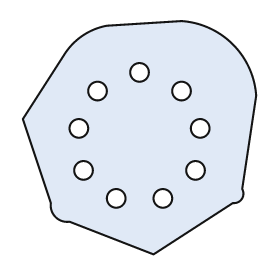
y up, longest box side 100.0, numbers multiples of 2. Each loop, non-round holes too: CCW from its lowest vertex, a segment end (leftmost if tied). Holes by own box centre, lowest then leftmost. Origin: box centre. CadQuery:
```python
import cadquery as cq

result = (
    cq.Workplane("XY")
    .moveTo(6.0, -50.0)
    .lineTo(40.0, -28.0)
    .threePointArc((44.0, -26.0), (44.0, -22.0))
    .lineTo(50.0, 18.0)
    .threePointArc((40.0, 40.0), (18.0, 50.0))
    .lineTo(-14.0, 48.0)
    .threePointArc((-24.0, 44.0), (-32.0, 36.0))
    .lineTo(-50.0, 8.0)
    .lineTo(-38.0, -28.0)
    .threePointArc((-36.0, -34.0), (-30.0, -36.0))
    .close()
    .moveTo(-10.0, -26.0)
    .circle(4.0)
    .moveTo(10.0, -26.0)
    .circle(4.0)
    .moveTo(-24.0, -14.0)
    .circle(4.0)
    .moveTo(24.0, -14.0)
    .circle(4.0)
    .moveTo(-26.0, 4.0)
    .circle(4.0)
    .moveTo(26.0, 4.0)
    .circle(4.0)
    .moveTo(-18.0, 20.0)
    .circle(4.0)
    .moveTo(18.0, 20.0)
    .circle(4.0)
    .moveTo(0.0, 28.0)
    .circle(4.0)
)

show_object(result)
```